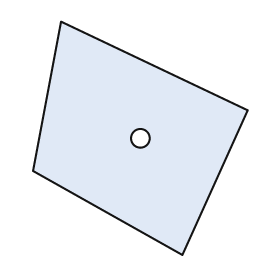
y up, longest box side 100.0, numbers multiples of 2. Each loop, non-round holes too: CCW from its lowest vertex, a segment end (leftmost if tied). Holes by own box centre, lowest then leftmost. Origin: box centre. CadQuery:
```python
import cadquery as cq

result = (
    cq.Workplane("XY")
    .moveTo(18.0, -50.0)
    .lineTo(46.0, 12.0)
    .lineTo(-34.0, 50.0)
    .lineTo(-46.0, -14.0)
    .close()
    .moveTo(0.0, 0.0)
    .circle(4.0)
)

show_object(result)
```